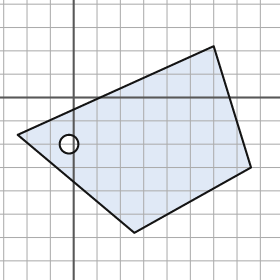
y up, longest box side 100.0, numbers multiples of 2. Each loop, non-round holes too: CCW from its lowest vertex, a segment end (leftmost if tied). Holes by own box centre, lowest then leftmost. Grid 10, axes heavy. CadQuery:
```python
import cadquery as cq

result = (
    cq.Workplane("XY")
    .moveTo(26.0, -58.0)
    .lineTo(76.0, -30.0)
    .lineTo(60.0, 22.0)
    .lineTo(-24.0, -16.0)
    .close()
    .moveTo(-2.0, -20.0)
    .circle(4.0)
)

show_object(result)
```